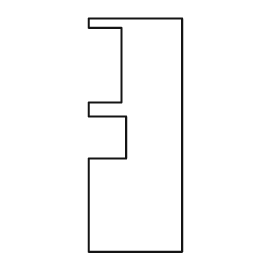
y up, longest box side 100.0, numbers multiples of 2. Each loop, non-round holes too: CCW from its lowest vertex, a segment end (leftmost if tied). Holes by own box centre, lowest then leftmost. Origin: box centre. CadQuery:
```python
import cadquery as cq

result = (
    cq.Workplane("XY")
    .moveTo(-20.0, -50.0)
    .lineTo(20.0, -50.0)
    .lineTo(20.0, 50.0)
    .lineTo(-20.0, 50.0)
    .lineTo(-20.0, 46.0)
    .lineTo(-6.0, 46.0)
    .lineTo(-6.0, 14.0)
    .lineTo(-20.0, 14.0)
    .lineTo(-20.0, 8.0)
    .lineTo(-4.0, 8.0)
    .lineTo(-4.0, -10.0)
    .lineTo(-20.0, -10.0)
    .close()
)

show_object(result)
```